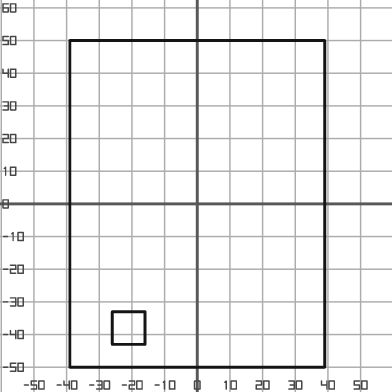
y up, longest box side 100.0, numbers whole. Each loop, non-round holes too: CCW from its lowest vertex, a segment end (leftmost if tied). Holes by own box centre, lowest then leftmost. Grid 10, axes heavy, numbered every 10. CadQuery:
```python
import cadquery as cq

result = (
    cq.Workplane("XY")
    .moveTo(-39.0, -50.0)
    .lineTo(39.0, -50.0)
    .lineTo(39.0, 50.0)
    .lineTo(-39.0, 50.0)
    .close()
    .moveTo(-26.0, -43.0)
    .lineTo(-16.0, -43.0)
    .lineTo(-16.0, -33.0)
    .lineTo(-26.0, -33.0)
    .close()
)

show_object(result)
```